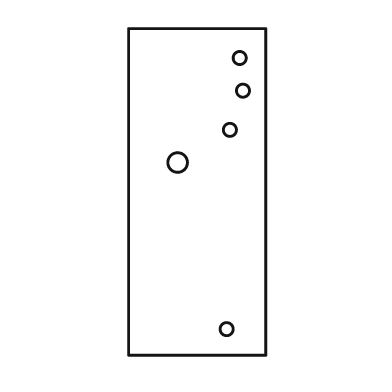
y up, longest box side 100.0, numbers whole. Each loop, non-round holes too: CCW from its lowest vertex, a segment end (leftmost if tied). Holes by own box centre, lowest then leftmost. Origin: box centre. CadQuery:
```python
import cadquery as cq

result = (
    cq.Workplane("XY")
    .moveTo(-21.0, -50.0)
    .lineTo(21.0, -50.0)
    .lineTo(21.0, 50.0)
    .lineTo(-21.0, 50.0)
    .close()
    .moveTo(9.0, -42.0)
    .circle(2.0)
    .moveTo(-6.0, 9.0)
    .circle(3.0)
    .moveTo(10.0, 19.0)
    .circle(2.0)
    .moveTo(14.0, 31.0)
    .circle(2.0)
    .moveTo(13.0, 41.0)
    .circle(2.0)
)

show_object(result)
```